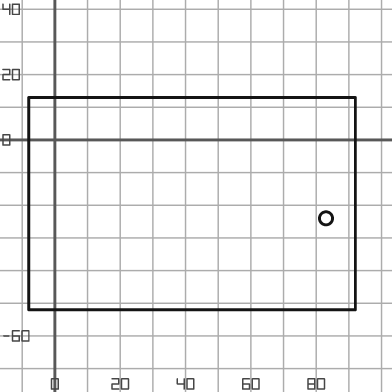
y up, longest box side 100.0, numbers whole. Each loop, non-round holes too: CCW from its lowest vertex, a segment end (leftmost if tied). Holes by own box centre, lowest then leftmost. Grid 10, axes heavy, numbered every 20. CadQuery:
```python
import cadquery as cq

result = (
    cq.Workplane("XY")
    .moveTo(-8.0, -52.0)
    .lineTo(92.0, -52.0)
    .lineTo(92.0, 13.0)
    .lineTo(-8.0, 13.0)
    .close()
    .moveTo(83.0, -24.0)
    .circle(2.0)
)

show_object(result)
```